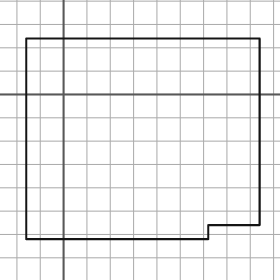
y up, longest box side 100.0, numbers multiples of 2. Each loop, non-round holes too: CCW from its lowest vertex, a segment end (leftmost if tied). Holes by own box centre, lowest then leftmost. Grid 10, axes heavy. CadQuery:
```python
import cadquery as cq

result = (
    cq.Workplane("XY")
    .moveTo(-16.0, -62.0)
    .lineTo(62.0, -62.0)
    .lineTo(62.0, -56.0)
    .lineTo(84.0, -56.0)
    .lineTo(84.0, 24.0)
    .lineTo(-16.0, 24.0)
    .close()
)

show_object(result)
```